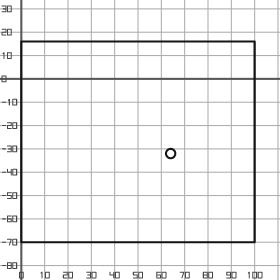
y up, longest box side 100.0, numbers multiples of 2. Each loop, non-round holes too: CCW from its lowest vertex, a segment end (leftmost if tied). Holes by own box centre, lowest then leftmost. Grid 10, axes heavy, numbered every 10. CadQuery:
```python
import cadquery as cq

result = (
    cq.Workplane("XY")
    .moveTo(0.0, -70.0)
    .lineTo(100.0, -70.0)
    .lineTo(100.0, 16.0)
    .lineTo(0.0, 16.0)
    .close()
    .moveTo(64.0, -32.0)
    .circle(2.0)
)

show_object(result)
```